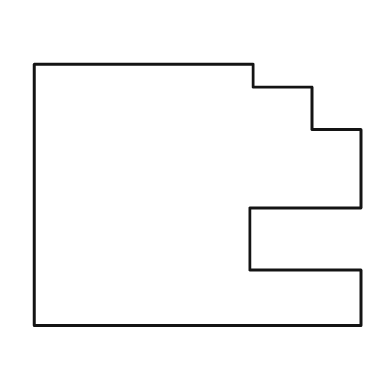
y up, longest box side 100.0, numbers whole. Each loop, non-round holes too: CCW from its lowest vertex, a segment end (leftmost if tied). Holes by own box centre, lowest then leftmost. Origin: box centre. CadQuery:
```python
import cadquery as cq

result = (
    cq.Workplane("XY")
    .moveTo(-50.0, -40.0)
    .lineTo(50.0, -40.0)
    .lineTo(50.0, -23.0)
    .lineTo(16.0, -23.0)
    .lineTo(16.0, -4.0)
    .lineTo(50.0, -4.0)
    .lineTo(50.0, 20.0)
    .lineTo(35.0, 20.0)
    .lineTo(35.0, 33.0)
    .lineTo(17.0, 33.0)
    .lineTo(17.0, 40.0)
    .lineTo(-50.0, 40.0)
    .close()
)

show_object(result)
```